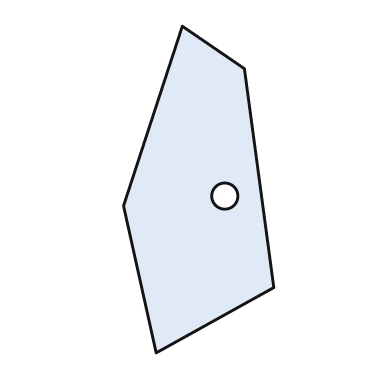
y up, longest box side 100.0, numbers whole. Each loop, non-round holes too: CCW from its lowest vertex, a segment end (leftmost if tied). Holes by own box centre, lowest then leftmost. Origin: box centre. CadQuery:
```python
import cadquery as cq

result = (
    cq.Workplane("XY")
    .moveTo(-13.0, -50.0)
    .lineTo(23.0, -30.0)
    .lineTo(14.0, 37.0)
    .lineTo(-5.0, 50.0)
    .lineTo(-23.0, -5.0)
    .close()
    .moveTo(8.0, -2.0)
    .circle(4.0)
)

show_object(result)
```